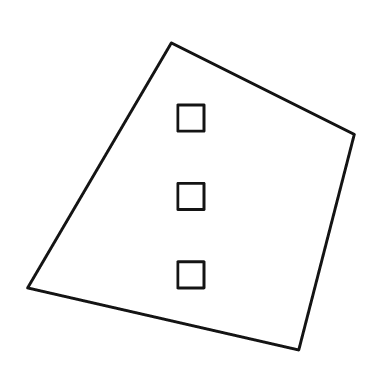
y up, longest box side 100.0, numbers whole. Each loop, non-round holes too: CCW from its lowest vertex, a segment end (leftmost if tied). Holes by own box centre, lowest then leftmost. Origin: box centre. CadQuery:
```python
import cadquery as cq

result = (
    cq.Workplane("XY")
    .moveTo(33.0, -47.0)
    .lineTo(50.0, 19.0)
    .lineTo(-6.0, 47.0)
    .lineTo(-50.0, -28.0)
    .close()
    .moveTo(-4.0, -28.0)
    .lineTo(4.0, -28.0)
    .lineTo(4.0, -20.0)
    .lineTo(-4.0, -20.0)
    .close()
    .moveTo(-4.0, -4.0)
    .lineTo(4.0, -4.0)
    .lineTo(4.0, 4.0)
    .lineTo(-4.0, 4.0)
    .close()
    .moveTo(-4.0, 20.0)
    .lineTo(4.0, 20.0)
    .lineTo(4.0, 28.0)
    .lineTo(-4.0, 28.0)
    .close()
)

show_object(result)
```